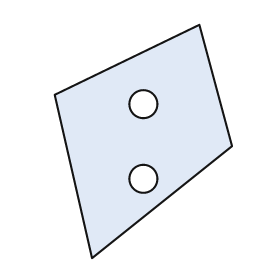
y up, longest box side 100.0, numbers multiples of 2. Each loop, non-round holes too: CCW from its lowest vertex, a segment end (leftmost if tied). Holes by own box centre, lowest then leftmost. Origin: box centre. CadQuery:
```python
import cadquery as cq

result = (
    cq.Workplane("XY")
    .moveTo(-22.0, -50.0)
    .lineTo(38.0, -2.0)
    .lineTo(24.0, 50.0)
    .lineTo(-38.0, 20.0)
    .close()
    .moveTo(0.0, -16.0)
    .circle(6.0)
    .moveTo(0.0, 16.0)
    .circle(6.0)
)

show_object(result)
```